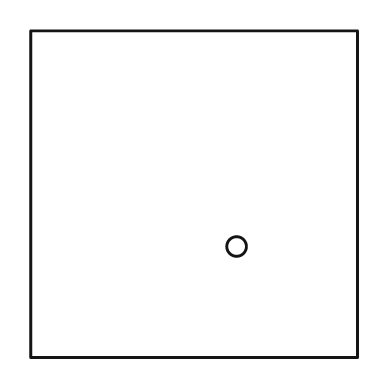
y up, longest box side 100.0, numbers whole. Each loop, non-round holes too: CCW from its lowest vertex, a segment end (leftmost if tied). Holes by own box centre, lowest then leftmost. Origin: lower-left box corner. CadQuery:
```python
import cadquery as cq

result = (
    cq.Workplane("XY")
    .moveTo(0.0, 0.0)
    .lineTo(100.0, 0.0)
    .lineTo(100.0, 100.0)
    .lineTo(0.0, 100.0)
    .close()
    .moveTo(63.0, 34.0)
    .circle(3.0)
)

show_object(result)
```